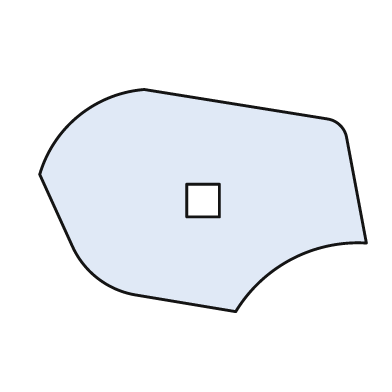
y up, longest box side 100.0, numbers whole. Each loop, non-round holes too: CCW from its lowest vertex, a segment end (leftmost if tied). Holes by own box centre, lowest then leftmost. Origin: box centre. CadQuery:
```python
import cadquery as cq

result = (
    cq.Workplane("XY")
    .moveTo(10.0, -34.0)
    .threePointArc((27.0, -18.0), (50.0, -13.0))
    .lineTo(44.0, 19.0)
    .threePointArc((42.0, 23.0), (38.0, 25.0))
    .lineTo(-18.0, 34.0)
    .threePointArc((-38.0, 26.0), (-50.0, 8.0))
    .lineTo(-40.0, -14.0)
    .threePointArc((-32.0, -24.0), (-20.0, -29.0))
    .close()
    .moveTo(-5.0, -5.0)
    .lineTo(5.0, -5.0)
    .lineTo(5.0, 5.0)
    .lineTo(-5.0, 5.0)
    .close()
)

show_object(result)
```